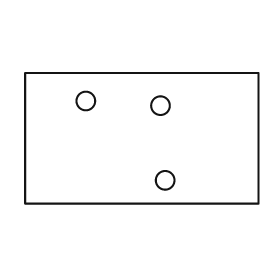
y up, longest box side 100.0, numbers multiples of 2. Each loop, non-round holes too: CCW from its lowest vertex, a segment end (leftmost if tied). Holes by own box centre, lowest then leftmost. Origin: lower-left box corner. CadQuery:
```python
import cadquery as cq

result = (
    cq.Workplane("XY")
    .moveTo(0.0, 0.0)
    .lineTo(100.0, 0.0)
    .lineTo(100.0, 56.0)
    .lineTo(0.0, 56.0)
    .close()
    .moveTo(60.0, 10.0)
    .circle(4.0)
    .moveTo(58.0, 42.0)
    .circle(4.0)
    .moveTo(26.0, 44.0)
    .circle(4.0)
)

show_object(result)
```